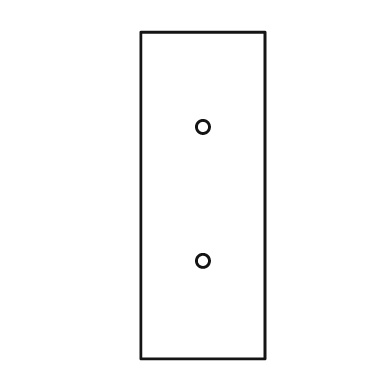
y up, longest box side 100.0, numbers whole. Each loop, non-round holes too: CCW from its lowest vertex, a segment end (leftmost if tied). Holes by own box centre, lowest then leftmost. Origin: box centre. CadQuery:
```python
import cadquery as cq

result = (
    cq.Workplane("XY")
    .moveTo(-19.0, -50.0)
    .lineTo(19.0, -50.0)
    .lineTo(19.0, 50.0)
    .lineTo(-19.0, 50.0)
    .close()
    .moveTo(0.0, -20.0)
    .circle(2.0)
    .moveTo(0.0, 21.0)
    .circle(2.0)
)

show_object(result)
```